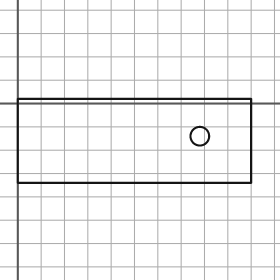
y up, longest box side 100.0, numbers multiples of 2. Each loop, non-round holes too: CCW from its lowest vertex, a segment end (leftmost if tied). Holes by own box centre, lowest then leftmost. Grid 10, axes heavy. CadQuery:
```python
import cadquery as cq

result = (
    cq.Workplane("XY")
    .moveTo(0.0, -34.0)
    .lineTo(100.0, -34.0)
    .lineTo(100.0, 2.0)
    .lineTo(0.0, 2.0)
    .close()
    .moveTo(78.0, -14.0)
    .circle(4.0)
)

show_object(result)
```